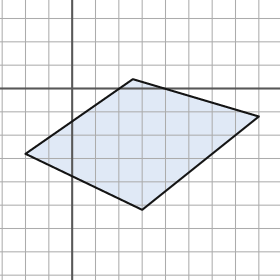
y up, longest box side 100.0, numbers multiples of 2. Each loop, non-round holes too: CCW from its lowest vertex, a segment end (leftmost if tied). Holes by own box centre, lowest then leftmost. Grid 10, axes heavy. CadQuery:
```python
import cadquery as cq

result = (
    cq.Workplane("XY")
    .moveTo(30.0, -52.0)
    .lineTo(80.0, -12.0)
    .lineTo(26.0, 4.0)
    .lineTo(-20.0, -28.0)
    .close()
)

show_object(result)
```